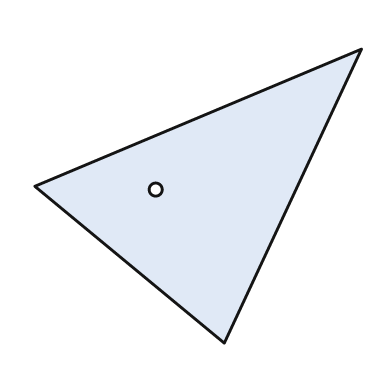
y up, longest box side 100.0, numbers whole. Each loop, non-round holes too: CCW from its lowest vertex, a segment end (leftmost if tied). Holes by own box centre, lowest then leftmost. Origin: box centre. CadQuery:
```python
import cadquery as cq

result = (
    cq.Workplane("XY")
    .moveTo(8.0, -45.0)
    .lineTo(50.0, 45.0)
    .lineTo(-50.0, 3.0)
    .close()
    .moveTo(-13.0, 2.0)
    .circle(2.0)
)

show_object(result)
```